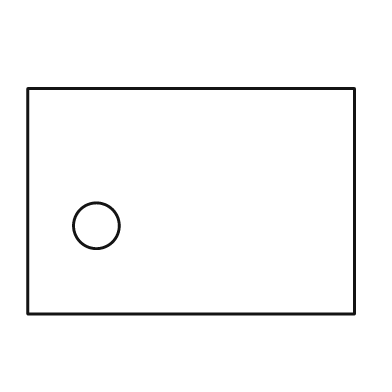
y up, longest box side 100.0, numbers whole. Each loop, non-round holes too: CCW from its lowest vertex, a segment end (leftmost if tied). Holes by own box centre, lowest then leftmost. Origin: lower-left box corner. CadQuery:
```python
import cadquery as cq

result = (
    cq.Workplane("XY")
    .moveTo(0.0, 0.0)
    .lineTo(100.0, 0.0)
    .lineTo(100.0, 69.0)
    .lineTo(0.0, 69.0)
    .close()
    .moveTo(21.0, 27.0)
    .circle(7.0)
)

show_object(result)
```